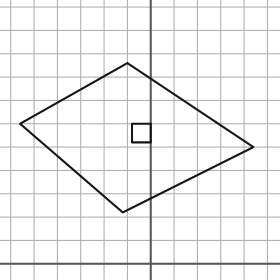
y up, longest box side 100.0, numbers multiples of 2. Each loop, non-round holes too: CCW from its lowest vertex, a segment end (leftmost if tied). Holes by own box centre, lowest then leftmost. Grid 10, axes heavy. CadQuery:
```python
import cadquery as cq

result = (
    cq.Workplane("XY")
    .moveTo(-12.0, 22.0)
    .lineTo(44.0, 50.0)
    .lineTo(-10.0, 86.0)
    .lineTo(-56.0, 60.0)
    .close()
    .moveTo(-8.0, 52.0)
    .lineTo(0.0, 52.0)
    .lineTo(0.0, 60.0)
    .lineTo(-8.0, 60.0)
    .close()
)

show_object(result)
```